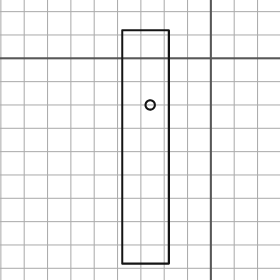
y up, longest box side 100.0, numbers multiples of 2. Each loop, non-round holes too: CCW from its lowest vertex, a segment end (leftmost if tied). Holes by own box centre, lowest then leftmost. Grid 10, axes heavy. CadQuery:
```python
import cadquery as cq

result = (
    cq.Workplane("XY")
    .moveTo(-38.0, -88.0)
    .lineTo(-18.0, -88.0)
    .lineTo(-18.0, 12.0)
    .lineTo(-38.0, 12.0)
    .close()
    .moveTo(-26.0, -20.0)
    .circle(2.0)
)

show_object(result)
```